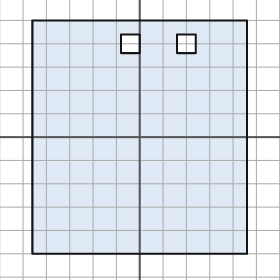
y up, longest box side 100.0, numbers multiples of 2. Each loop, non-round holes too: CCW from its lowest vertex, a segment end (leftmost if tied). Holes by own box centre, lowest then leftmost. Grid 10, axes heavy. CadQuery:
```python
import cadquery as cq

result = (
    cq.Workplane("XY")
    .moveTo(-46.0, -50.0)
    .lineTo(46.0, -50.0)
    .lineTo(46.0, 50.0)
    .lineTo(-46.0, 50.0)
    .close()
    .moveTo(-8.0, 36.0)
    .lineTo(0.0, 36.0)
    .lineTo(0.0, 44.0)
    .lineTo(-8.0, 44.0)
    .close()
    .moveTo(16.0, 36.0)
    .lineTo(24.0, 36.0)
    .lineTo(24.0, 44.0)
    .lineTo(16.0, 44.0)
    .close()
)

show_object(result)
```